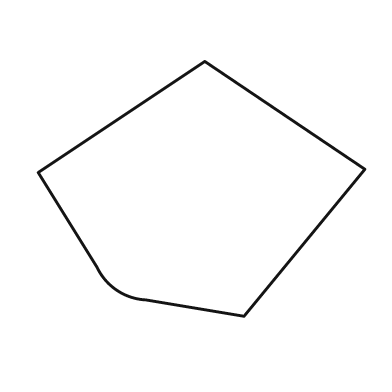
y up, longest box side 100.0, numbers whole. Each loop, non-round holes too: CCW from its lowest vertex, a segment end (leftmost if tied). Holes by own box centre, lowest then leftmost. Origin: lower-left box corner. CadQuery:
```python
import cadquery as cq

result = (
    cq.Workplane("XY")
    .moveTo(63.0, 0.0)
    .lineTo(100.0, 45.0)
    .lineTo(51.0, 78.0)
    .lineTo(0.0, 44.0)
    .lineTo(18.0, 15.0)
    .threePointArc((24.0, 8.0), (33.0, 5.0))
    .close()
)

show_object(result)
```